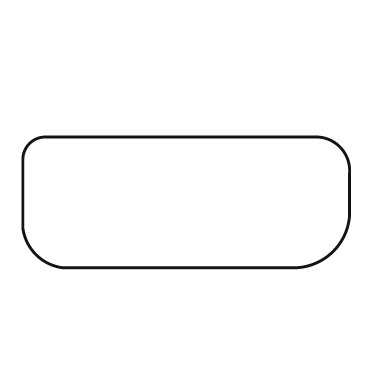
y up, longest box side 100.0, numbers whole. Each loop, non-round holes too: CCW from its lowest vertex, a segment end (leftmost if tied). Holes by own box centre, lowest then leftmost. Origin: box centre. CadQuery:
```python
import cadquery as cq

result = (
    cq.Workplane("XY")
    .moveTo(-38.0, -20.0)
    .lineTo(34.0, -20.0)
    .threePointArc((45.0, -15.0), (50.0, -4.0))
    .lineTo(50.0, 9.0)
    .threePointArc((47.0, 17.0), (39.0, 20.0))
    .lineTo(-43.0, 20.0)
    .threePointArc((-48.0, 18.0), (-50.0, 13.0))
    .lineTo(-50.0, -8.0)
    .threePointArc((-46.0, -16.0), (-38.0, -20.0))
    .close()
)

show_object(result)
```